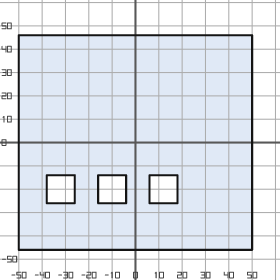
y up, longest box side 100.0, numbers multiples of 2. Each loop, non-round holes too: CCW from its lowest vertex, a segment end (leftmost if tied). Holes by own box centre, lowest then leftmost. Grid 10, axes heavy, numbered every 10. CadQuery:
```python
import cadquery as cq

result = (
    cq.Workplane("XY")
    .moveTo(-50.0, -46.0)
    .lineTo(50.0, -46.0)
    .lineTo(50.0, 46.0)
    .lineTo(-50.0, 46.0)
    .close()
    .moveTo(-38.0, -26.0)
    .lineTo(-26.0, -26.0)
    .lineTo(-26.0, -14.0)
    .lineTo(-38.0, -14.0)
    .close()
    .moveTo(-16.0, -26.0)
    .lineTo(-4.0, -26.0)
    .lineTo(-4.0, -14.0)
    .lineTo(-16.0, -14.0)
    .close()
    .moveTo(6.0, -26.0)
    .lineTo(18.0, -26.0)
    .lineTo(18.0, -14.0)
    .lineTo(6.0, -14.0)
    .close()
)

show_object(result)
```